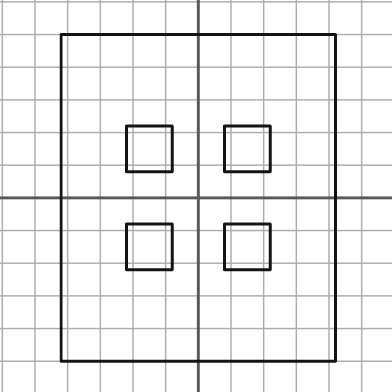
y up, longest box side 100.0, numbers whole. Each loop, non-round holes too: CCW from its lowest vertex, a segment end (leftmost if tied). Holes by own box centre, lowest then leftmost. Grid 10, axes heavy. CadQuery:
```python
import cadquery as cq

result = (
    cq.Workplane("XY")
    .moveTo(-42.0, -50.0)
    .lineTo(42.0, -50.0)
    .lineTo(42.0, 50.0)
    .lineTo(-42.0, 50.0)
    .close()
    .moveTo(-22.0, -22.0)
    .lineTo(-8.0, -22.0)
    .lineTo(-8.0, -8.0)
    .lineTo(-22.0, -8.0)
    .close()
    .moveTo(8.0, -22.0)
    .lineTo(22.0, -22.0)
    .lineTo(22.0, -8.0)
    .lineTo(8.0, -8.0)
    .close()
    .moveTo(-22.0, 8.0)
    .lineTo(-8.0, 8.0)
    .lineTo(-8.0, 22.0)
    .lineTo(-22.0, 22.0)
    .close()
    .moveTo(8.0, 8.0)
    .lineTo(22.0, 8.0)
    .lineTo(22.0, 22.0)
    .lineTo(8.0, 22.0)
    .close()
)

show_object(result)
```